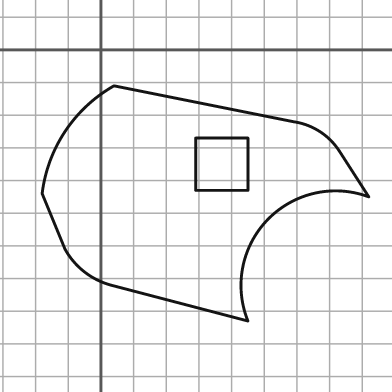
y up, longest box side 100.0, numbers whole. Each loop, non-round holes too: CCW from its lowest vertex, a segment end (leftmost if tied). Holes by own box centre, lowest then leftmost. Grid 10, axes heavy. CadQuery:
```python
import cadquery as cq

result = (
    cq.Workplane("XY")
    .moveTo(45.0, -83.0)
    .threePointArc((51.0, -52.0), (82.0, -45.0))
    .lineTo(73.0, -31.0)
    .threePointArc((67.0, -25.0), (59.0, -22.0))
    .lineTo(4.0, -11.0)
    .threePointArc((-11.0, -25.0), (-18.0, -44.0))
    .lineTo(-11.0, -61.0)
    .threePointArc((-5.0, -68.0), (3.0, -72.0))
    .close()
    .moveTo(29.0, -43.0)
    .lineTo(45.0, -43.0)
    .lineTo(45.0, -27.0)
    .lineTo(29.0, -27.0)
    .close()
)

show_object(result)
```